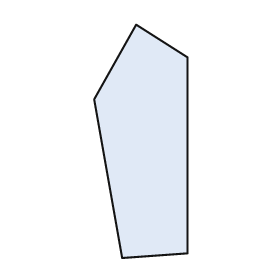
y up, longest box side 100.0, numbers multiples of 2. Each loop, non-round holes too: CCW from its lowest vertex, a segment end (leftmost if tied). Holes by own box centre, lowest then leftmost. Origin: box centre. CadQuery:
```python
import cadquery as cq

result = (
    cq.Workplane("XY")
    .moveTo(-8.0, -50.0)
    .lineTo(20.0, -48.0)
    .lineTo(20.0, 36.0)
    .lineTo(-2.0, 50.0)
    .lineTo(-20.0, 18.0)
    .close()
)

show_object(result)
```